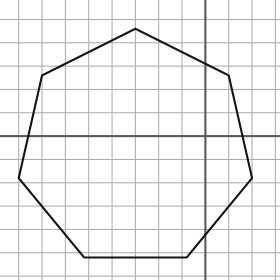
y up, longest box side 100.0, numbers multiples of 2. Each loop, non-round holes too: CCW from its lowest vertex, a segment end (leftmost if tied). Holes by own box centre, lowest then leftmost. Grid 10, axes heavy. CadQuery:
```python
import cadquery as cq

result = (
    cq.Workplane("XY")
    .moveTo(-52.0, -52.0)
    .lineTo(-8.0, -52.0)
    .lineTo(20.0, -18.0)
    .lineTo(10.0, 26.0)
    .lineTo(-30.0, 46.0)
    .lineTo(-70.0, 26.0)
    .lineTo(-80.0, -18.0)
    .close()
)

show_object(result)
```